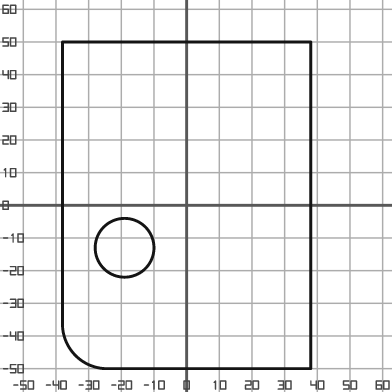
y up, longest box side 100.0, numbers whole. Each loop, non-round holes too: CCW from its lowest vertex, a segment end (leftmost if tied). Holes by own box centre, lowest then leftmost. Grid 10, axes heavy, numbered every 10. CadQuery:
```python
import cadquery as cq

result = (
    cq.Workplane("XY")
    .moveTo(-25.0, -50.0)
    .lineTo(38.0, -50.0)
    .lineTo(38.0, 50.0)
    .lineTo(-38.0, 50.0)
    .lineTo(-38.0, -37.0)
    .threePointArc((-34.0, -46.0), (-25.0, -50.0))
    .close()
    .moveTo(-19.0, -13.0)
    .circle(9.0)
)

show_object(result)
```